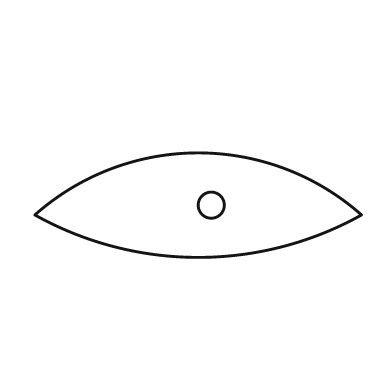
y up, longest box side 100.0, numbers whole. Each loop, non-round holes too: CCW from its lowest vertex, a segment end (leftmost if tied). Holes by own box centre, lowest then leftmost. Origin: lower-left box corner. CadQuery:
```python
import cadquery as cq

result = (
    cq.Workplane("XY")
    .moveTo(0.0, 13.0)
    .threePointArc((50.0, 0.0), (100.0, 13.0))
    .threePointArc((50.0, 32.0), (0.0, 13.0))
    .close()
    .moveTo(54.0, 16.0)
    .circle(4.0)
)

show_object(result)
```